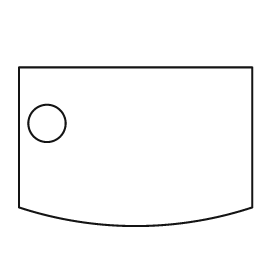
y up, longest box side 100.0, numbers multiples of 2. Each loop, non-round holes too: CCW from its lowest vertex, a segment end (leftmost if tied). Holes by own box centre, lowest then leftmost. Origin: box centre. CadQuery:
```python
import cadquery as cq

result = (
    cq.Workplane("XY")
    .moveTo(-50.0, -26.0)
    .threePointArc((0.0, -34.0), (50.0, -26.0))
    .lineTo(50.0, 34.0)
    .lineTo(-50.0, 34.0)
    .close()
    .moveTo(-38.0, 10.0)
    .circle(8.0)
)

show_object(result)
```